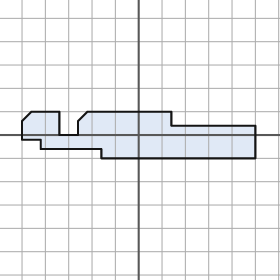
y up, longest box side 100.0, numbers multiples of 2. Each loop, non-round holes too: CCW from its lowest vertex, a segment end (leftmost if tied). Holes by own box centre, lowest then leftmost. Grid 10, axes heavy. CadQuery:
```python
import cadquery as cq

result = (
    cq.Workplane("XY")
    .moveTo(-16.0, -10.0)
    .lineTo(50.0, -10.0)
    .lineTo(50.0, 4.0)
    .lineTo(14.0, 4.0)
    .lineTo(14.0, 10.0)
    .lineTo(-22.0, 10.0)
    .lineTo(-26.0, 6.0)
    .lineTo(-26.0, 0.0)
    .lineTo(-34.0, 0.0)
    .lineTo(-34.0, 10.0)
    .lineTo(-46.0, 10.0)
    .lineTo(-50.0, 6.0)
    .lineTo(-50.0, -2.0)
    .lineTo(-42.0, -2.0)
    .lineTo(-42.0, -6.0)
    .lineTo(-16.0, -6.0)
    .close()
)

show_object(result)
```